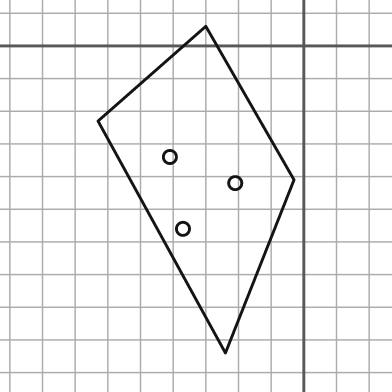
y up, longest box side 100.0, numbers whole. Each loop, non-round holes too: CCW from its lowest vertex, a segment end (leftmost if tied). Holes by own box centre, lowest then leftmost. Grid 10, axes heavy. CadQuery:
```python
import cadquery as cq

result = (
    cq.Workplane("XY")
    .moveTo(-24.0, -94.0)
    .lineTo(-3.0, -41.0)
    .lineTo(-30.0, 6.0)
    .lineTo(-63.0, -23.0)
    .close()
    .moveTo(-37.0, -56.0)
    .circle(2.0)
    .moveTo(-21.0, -42.0)
    .circle(2.0)
    .moveTo(-41.0, -34.0)
    .circle(2.0)
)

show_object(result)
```